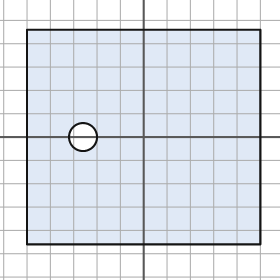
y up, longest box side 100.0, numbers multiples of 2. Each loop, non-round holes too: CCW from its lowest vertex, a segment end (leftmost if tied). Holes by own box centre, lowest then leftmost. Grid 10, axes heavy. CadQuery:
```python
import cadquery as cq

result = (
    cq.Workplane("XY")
    .moveTo(-50.0, -46.0)
    .lineTo(50.0, -46.0)
    .lineTo(50.0, 46.0)
    .lineTo(-50.0, 46.0)
    .close()
    .moveTo(-26.0, 0.0)
    .circle(6.0)
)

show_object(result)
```